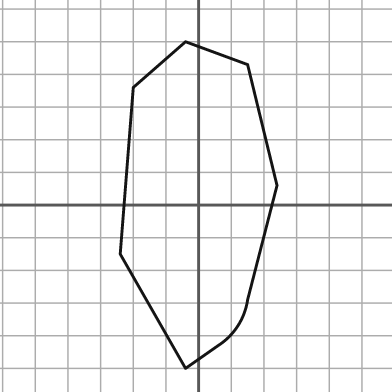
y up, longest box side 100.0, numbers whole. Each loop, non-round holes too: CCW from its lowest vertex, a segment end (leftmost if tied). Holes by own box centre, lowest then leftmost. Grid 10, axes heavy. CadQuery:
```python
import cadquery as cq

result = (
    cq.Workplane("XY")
    .moveTo(-4.0, -50.0)
    .lineTo(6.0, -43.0)
    .threePointArc((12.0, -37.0), (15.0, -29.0))
    .lineTo(24.0, 6.0)
    .lineTo(15.0, 43.0)
    .lineTo(-4.0, 50.0)
    .lineTo(-20.0, 36.0)
    .lineTo(-24.0, -15.0)
    .close()
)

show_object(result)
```